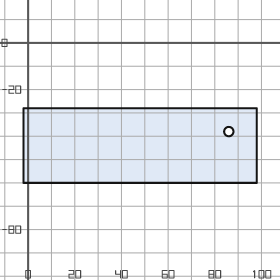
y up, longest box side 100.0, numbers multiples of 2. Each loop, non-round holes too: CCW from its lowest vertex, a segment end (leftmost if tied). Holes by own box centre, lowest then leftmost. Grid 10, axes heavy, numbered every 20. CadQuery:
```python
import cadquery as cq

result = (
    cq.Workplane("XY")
    .moveTo(-2.0, -60.0)
    .lineTo(98.0, -60.0)
    .lineTo(98.0, -28.0)
    .lineTo(-2.0, -28.0)
    .close()
    .moveTo(86.0, -38.0)
    .circle(2.0)
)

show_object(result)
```